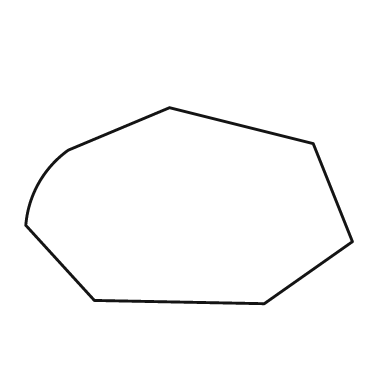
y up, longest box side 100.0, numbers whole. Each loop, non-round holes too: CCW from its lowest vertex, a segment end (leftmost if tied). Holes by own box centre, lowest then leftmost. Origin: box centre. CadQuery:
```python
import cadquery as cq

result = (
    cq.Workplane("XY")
    .moveTo(23.0, -30.0)
    .lineTo(50.0, -11.0)
    .lineTo(38.0, 19.0)
    .lineTo(-6.0, 30.0)
    .lineTo(-37.0, 17.0)
    .threePointArc((-46.0, 7.0), (-50.0, -6.0))
    .lineTo(-29.0, -29.0)
    .close()
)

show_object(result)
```